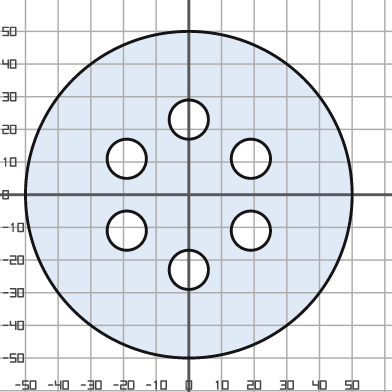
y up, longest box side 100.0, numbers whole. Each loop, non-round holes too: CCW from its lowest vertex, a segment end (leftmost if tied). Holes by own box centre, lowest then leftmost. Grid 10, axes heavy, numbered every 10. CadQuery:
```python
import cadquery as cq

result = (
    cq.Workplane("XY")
    .moveTo(0.0, 0.0)
    .circle(50.0)
    .moveTo(0.0, -23.0)
    .circle(6.0)
    .moveTo(-19.0, -11.0)
    .circle(6.0)
    .moveTo(19.0, -11.0)
    .circle(6.0)
    .moveTo(-19.0, 11.0)
    .circle(6.0)
    .moveTo(19.0, 11.0)
    .circle(6.0)
    .moveTo(0.0, 23.0)
    .circle(6.0)
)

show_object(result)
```